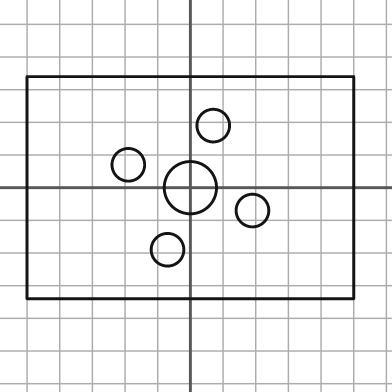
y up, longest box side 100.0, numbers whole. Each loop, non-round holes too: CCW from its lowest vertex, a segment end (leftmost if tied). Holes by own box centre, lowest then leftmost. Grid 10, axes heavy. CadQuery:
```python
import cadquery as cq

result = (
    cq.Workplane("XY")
    .moveTo(-50.0, -34.0)
    .lineTo(50.0, -34.0)
    .lineTo(50.0, 34.0)
    .lineTo(-50.0, 34.0)
    .close()
    .moveTo(-7.0, -19.0)
    .circle(5.0)
    .moveTo(19.0, -7.0)
    .circle(5.0)
    .moveTo(0.0, 0.0)
    .circle(8.0)
    .moveTo(-19.0, 7.0)
    .circle(5.0)
    .moveTo(7.0, 19.0)
    .circle(5.0)
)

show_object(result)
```